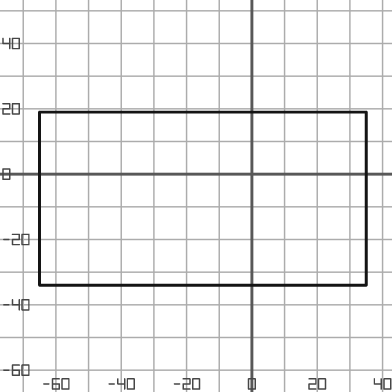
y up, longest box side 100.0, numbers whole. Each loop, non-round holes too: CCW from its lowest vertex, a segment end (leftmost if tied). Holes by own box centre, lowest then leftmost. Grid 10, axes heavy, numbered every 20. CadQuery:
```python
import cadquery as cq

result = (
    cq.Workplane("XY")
    .moveTo(-65.0, -34.0)
    .lineTo(35.0, -34.0)
    .lineTo(35.0, 19.0)
    .lineTo(-65.0, 19.0)
    .close()
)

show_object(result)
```